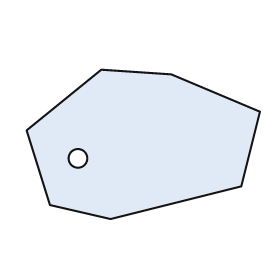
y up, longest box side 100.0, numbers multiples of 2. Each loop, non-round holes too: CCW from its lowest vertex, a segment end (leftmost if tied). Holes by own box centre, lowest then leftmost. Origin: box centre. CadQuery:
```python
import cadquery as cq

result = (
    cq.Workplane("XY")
    .moveTo(-14.0, -32.0)
    .lineTo(42.0, -18.0)
    .lineTo(50.0, 14.0)
    .lineTo(12.0, 30.0)
    .lineTo(-18.0, 32.0)
    .lineTo(-50.0, 6.0)
    .lineTo(-40.0, -26.0)
    .close()
    .moveTo(-28.0, -6.0)
    .circle(4.0)
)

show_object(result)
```